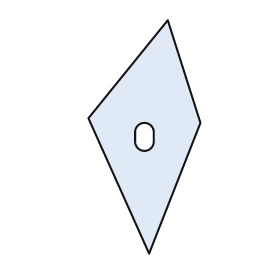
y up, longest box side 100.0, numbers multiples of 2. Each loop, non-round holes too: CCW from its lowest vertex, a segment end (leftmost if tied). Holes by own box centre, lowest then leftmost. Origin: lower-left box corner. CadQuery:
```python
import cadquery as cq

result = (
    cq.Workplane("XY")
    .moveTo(26.0, 0.0)
    .lineTo(48.0, 56.0)
    .lineTo(34.0, 100.0)
    .lineTo(0.0, 58.0)
    .close()
    .moveTo(20.0, 48.0)
    .threePointArc((24.0, 44.0), (28.0, 48.0))
    .lineTo(28.0, 52.0)
    .threePointArc((24.0, 56.0), (20.0, 52.0))
    .close()
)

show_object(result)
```